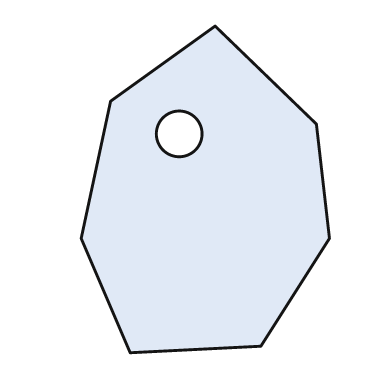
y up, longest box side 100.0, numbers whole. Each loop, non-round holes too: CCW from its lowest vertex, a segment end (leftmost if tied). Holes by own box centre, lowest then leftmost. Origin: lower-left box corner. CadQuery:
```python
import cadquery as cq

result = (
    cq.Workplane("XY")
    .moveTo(15.0, 0.0)
    .lineTo(55.0, 2.0)
    .lineTo(76.0, 35.0)
    .lineTo(72.0, 70.0)
    .lineTo(41.0, 100.0)
    .lineTo(9.0, 77.0)
    .lineTo(0.0, 35.0)
    .close()
    .moveTo(30.0, 67.0)
    .circle(7.0)
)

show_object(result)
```